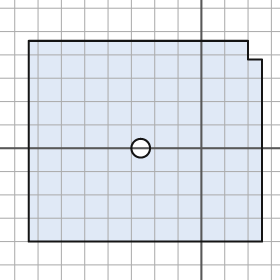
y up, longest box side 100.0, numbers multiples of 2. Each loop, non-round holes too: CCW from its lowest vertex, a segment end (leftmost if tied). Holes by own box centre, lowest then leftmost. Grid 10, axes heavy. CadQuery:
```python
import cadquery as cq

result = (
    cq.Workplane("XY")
    .moveTo(-74.0, -40.0)
    .lineTo(26.0, -40.0)
    .lineTo(26.0, 38.0)
    .lineTo(20.0, 38.0)
    .lineTo(20.0, 46.0)
    .lineTo(-74.0, 46.0)
    .close()
    .moveTo(-26.0, 0.0)
    .circle(4.0)
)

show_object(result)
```